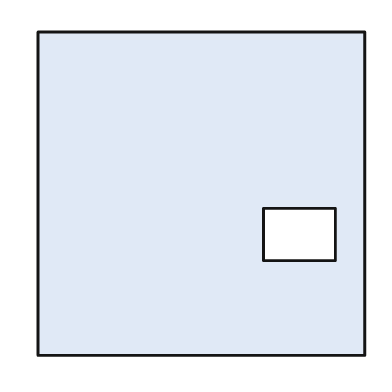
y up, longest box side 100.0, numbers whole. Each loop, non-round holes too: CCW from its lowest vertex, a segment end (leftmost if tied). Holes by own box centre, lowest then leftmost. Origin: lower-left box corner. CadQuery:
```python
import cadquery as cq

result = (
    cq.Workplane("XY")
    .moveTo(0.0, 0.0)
    .lineTo(100.0, 0.0)
    .lineTo(100.0, 99.0)
    .lineTo(0.0, 99.0)
    .close()
    .moveTo(69.0, 29.0)
    .lineTo(91.0, 29.0)
    .lineTo(91.0, 45.0)
    .lineTo(69.0, 45.0)
    .close()
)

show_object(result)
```